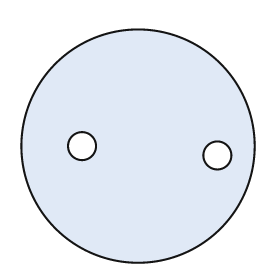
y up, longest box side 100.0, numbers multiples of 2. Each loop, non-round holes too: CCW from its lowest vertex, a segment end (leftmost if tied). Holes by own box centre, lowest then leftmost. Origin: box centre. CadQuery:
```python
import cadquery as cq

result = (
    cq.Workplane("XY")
    .moveTo(0.0, 0.0)
    .circle(50.0)
    .moveTo(34.0, -4.0)
    .circle(6.0)
    .moveTo(-24.0, 0.0)
    .circle(6.0)
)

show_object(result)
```